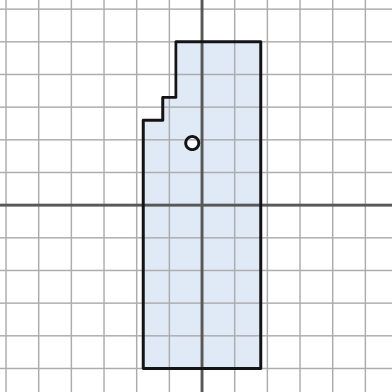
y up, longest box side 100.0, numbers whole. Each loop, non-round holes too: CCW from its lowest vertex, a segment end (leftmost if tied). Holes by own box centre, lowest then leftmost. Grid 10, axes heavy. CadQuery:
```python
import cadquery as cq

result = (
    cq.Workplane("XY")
    .moveTo(-18.0, -50.0)
    .lineTo(18.0, -50.0)
    .lineTo(18.0, 50.0)
    .lineTo(-8.0, 50.0)
    .lineTo(-8.0, 33.0)
    .lineTo(-12.0, 33.0)
    .lineTo(-12.0, 26.0)
    .lineTo(-18.0, 26.0)
    .close()
    .moveTo(-3.0, 19.0)
    .circle(2.0)
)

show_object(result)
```